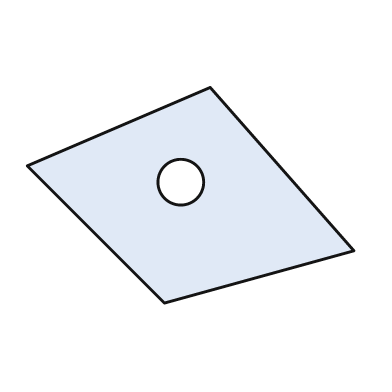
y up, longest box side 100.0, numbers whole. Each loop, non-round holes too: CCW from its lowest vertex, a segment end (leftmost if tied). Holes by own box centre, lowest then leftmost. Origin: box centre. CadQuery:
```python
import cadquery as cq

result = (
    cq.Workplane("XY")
    .moveTo(-8.0, -33.0)
    .lineTo(50.0, -17.0)
    .lineTo(6.0, 33.0)
    .lineTo(-50.0, 9.0)
    .close()
    .moveTo(-3.0, 4.0)
    .circle(7.0)
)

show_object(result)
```